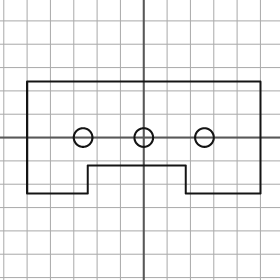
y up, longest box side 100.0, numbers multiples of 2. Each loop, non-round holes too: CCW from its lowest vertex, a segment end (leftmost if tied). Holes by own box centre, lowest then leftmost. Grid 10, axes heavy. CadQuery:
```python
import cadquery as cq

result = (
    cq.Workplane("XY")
    .moveTo(-50.0, -24.0)
    .lineTo(-24.0, -24.0)
    .lineTo(-24.0, -12.0)
    .lineTo(18.0, -12.0)
    .lineTo(18.0, -24.0)
    .lineTo(50.0, -24.0)
    .lineTo(50.0, 24.0)
    .lineTo(-50.0, 24.0)
    .close()
    .moveTo(-26.0, 0.0)
    .circle(4.0)
    .moveTo(0.0, 0.0)
    .circle(4.0)
    .moveTo(26.0, 0.0)
    .circle(4.0)
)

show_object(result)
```